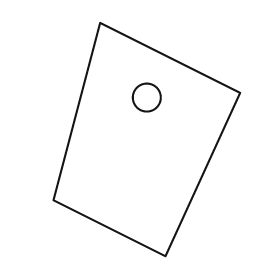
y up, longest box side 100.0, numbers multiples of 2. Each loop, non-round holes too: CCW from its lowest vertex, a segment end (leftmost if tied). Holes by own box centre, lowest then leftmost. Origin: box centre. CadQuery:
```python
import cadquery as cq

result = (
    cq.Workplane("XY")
    .moveTo(8.0, -50.0)
    .lineTo(40.0, 20.0)
    .lineTo(-20.0, 50.0)
    .lineTo(-40.0, -26.0)
    .close()
    .moveTo(0.0, 18.0)
    .circle(6.0)
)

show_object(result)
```